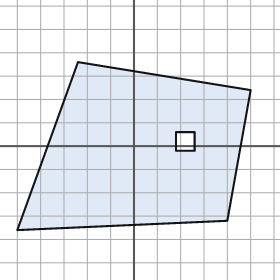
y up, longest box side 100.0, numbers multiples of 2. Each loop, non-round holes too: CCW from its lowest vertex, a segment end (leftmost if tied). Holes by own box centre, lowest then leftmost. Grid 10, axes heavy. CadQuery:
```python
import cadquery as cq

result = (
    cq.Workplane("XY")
    .moveTo(-50.0, -36.0)
    .lineTo(40.0, -32.0)
    .lineTo(50.0, 24.0)
    .lineTo(-24.0, 36.0)
    .close()
    .moveTo(18.0, -2.0)
    .lineTo(26.0, -2.0)
    .lineTo(26.0, 6.0)
    .lineTo(18.0, 6.0)
    .close()
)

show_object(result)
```